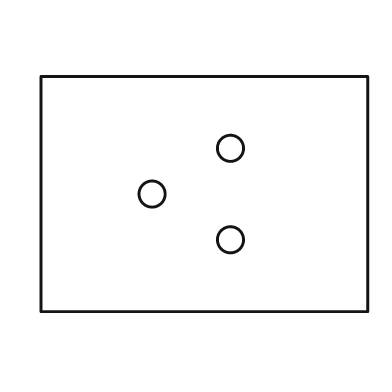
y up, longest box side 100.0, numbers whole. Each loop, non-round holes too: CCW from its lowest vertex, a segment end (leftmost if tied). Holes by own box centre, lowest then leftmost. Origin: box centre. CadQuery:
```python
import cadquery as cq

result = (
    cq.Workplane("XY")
    .moveTo(-50.0, -36.0)
    .lineTo(50.0, -36.0)
    .lineTo(50.0, 36.0)
    .lineTo(-50.0, 36.0)
    .close()
    .moveTo(8.0, -14.0)
    .circle(4.0)
    .moveTo(-16.0, 0.0)
    .circle(4.0)
    .moveTo(8.0, 14.0)
    .circle(4.0)
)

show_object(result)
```